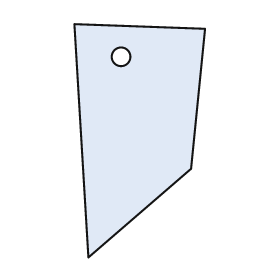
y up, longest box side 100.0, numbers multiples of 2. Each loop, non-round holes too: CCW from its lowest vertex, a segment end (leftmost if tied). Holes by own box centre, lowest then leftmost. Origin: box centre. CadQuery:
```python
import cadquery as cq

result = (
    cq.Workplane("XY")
    .moveTo(-22.0, -50.0)
    .lineTo(22.0, -12.0)
    .lineTo(28.0, 48.0)
    .lineTo(-28.0, 50.0)
    .close()
    .moveTo(-8.0, 36.0)
    .circle(4.0)
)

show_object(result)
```